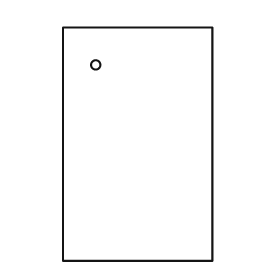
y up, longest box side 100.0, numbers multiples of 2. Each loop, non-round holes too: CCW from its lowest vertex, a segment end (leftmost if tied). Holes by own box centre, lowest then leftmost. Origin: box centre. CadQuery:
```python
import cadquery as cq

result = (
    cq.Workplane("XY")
    .moveTo(-32.0, -50.0)
    .lineTo(32.0, -50.0)
    .lineTo(32.0, 50.0)
    .lineTo(-32.0, 50.0)
    .close()
    .moveTo(-18.0, 34.0)
    .circle(2.0)
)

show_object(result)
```